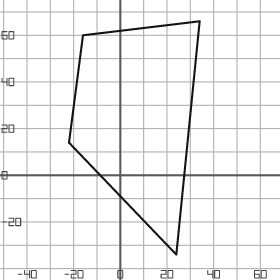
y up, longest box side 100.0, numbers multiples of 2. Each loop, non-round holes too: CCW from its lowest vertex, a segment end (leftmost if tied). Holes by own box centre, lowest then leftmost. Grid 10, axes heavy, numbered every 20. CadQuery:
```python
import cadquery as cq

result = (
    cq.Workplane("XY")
    .moveTo(24.0, -34.0)
    .lineTo(34.0, 66.0)
    .lineTo(-16.0, 60.0)
    .lineTo(-22.0, 14.0)
    .close()
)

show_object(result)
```